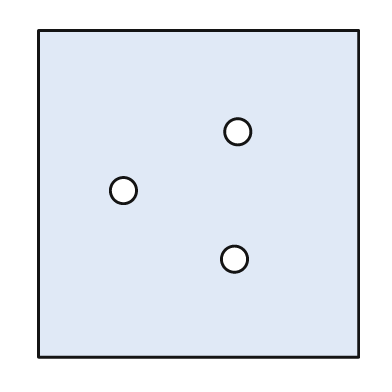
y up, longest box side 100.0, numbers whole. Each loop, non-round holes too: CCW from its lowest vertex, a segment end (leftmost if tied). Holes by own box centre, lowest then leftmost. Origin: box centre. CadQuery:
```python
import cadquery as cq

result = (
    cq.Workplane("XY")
    .moveTo(-49.0, -50.0)
    .lineTo(49.0, -50.0)
    .lineTo(49.0, 50.0)
    .lineTo(-49.0, 50.0)
    .close()
    .moveTo(11.0, -20.0)
    .circle(4.0)
    .moveTo(-23.0, 1.0)
    .circle(4.0)
    .moveTo(12.0, 19.0)
    .circle(4.0)
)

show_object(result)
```